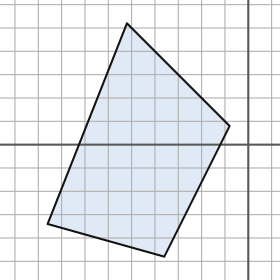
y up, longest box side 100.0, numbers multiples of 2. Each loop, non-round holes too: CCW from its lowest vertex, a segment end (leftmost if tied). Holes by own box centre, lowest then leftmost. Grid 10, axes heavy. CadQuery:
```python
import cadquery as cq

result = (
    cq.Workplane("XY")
    .moveTo(-36.0, -48.0)
    .lineTo(-8.0, 8.0)
    .lineTo(-52.0, 52.0)
    .lineTo(-86.0, -34.0)
    .close()
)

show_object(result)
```